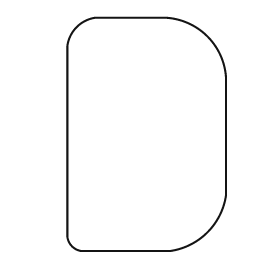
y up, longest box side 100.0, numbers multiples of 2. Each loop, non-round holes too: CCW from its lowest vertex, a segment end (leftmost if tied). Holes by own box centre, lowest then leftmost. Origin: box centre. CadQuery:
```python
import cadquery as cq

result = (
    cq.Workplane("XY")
    .moveTo(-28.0, -50.0)
    .lineTo(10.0, -50.0)
    .threePointArc((26.0, -42.0), (34.0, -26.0))
    .lineTo(34.0, 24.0)
    .threePointArc((26.0, 42.0), (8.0, 50.0))
    .lineTo(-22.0, 50.0)
    .threePointArc((-30.0, 46.0), (-34.0, 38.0))
    .lineTo(-34.0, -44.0)
    .threePointArc((-32.0, -48.0), (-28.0, -50.0))
    .close()
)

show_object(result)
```